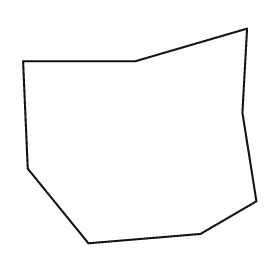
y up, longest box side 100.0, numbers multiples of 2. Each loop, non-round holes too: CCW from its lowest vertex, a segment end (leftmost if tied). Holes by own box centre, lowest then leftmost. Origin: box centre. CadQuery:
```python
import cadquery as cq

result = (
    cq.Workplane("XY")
    .moveTo(-22.0, -46.0)
    .lineTo(26.0, -42.0)
    .lineTo(50.0, -28.0)
    .lineTo(44.0, 10.0)
    .lineTo(46.0, 46.0)
    .lineTo(-2.0, 32.0)
    .lineTo(-50.0, 32.0)
    .lineTo(-48.0, -14.0)
    .close()
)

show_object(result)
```